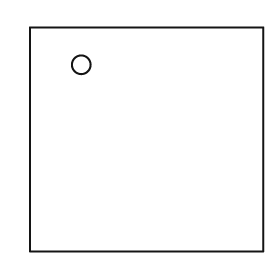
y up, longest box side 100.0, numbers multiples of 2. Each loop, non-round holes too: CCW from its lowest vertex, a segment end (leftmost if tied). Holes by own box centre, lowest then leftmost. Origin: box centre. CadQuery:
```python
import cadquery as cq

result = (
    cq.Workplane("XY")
    .moveTo(-50.0, -48.0)
    .lineTo(50.0, -48.0)
    .lineTo(50.0, 48.0)
    .lineTo(-50.0, 48.0)
    .close()
    .moveTo(-28.0, 32.0)
    .circle(4.0)
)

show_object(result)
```